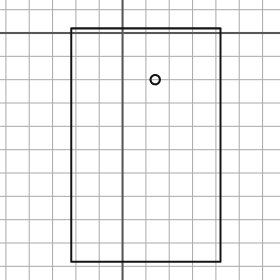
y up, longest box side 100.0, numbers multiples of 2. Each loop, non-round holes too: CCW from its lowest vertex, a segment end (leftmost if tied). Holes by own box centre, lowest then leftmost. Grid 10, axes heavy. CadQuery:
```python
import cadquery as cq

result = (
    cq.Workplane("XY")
    .moveTo(-22.0, -98.0)
    .lineTo(42.0, -98.0)
    .lineTo(42.0, 2.0)
    .lineTo(-22.0, 2.0)
    .close()
    .moveTo(14.0, -20.0)
    .circle(2.0)
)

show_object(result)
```